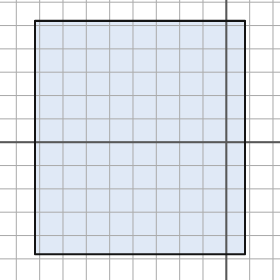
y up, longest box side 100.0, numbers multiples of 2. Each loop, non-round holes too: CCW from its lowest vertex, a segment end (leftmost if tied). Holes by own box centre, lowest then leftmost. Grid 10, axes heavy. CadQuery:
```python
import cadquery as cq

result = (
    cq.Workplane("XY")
    .moveTo(-82.0, -48.0)
    .lineTo(8.0, -48.0)
    .lineTo(8.0, 52.0)
    .lineTo(-82.0, 52.0)
    .close()
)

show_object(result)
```